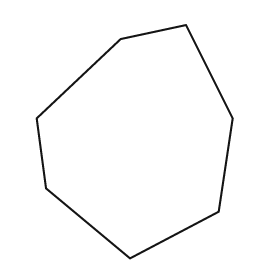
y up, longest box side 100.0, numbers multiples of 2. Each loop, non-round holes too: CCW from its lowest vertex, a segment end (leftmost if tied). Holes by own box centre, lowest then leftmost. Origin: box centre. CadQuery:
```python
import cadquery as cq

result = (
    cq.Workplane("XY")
    .moveTo(-2.0, -50.0)
    .lineTo(36.0, -30.0)
    .lineTo(42.0, 10.0)
    .lineTo(22.0, 50.0)
    .lineTo(-6.0, 44.0)
    .lineTo(-42.0, 10.0)
    .lineTo(-38.0, -20.0)
    .close()
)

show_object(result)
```